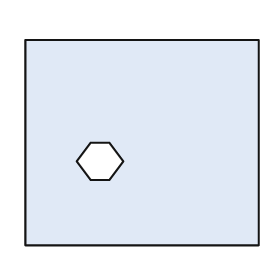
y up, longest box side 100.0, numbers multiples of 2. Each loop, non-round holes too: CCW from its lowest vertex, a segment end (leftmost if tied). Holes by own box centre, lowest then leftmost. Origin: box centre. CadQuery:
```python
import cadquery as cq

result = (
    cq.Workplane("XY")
    .moveTo(-50.0, -44.0)
    .lineTo(50.0, -44.0)
    .lineTo(50.0, 44.0)
    .lineTo(-50.0, 44.0)
    .close()
    .moveTo(-22.0, -16.0)
    .lineTo(-14.0, -16.0)
    .lineTo(-8.0, -8.0)
    .lineTo(-14.0, 0.0)
    .lineTo(-22.0, 0.0)
    .lineTo(-28.0, -8.0)
    .close()
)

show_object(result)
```